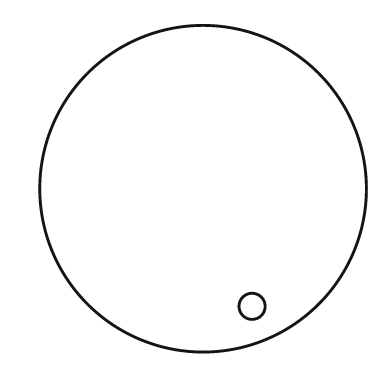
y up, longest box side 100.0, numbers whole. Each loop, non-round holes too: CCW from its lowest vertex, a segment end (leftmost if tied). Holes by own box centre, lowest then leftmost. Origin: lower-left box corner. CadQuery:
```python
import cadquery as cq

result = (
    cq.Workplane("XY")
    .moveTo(50.0, 50.0)
    .circle(50.0)
    .moveTo(65.0, 14.0)
    .circle(4.0)
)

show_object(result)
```